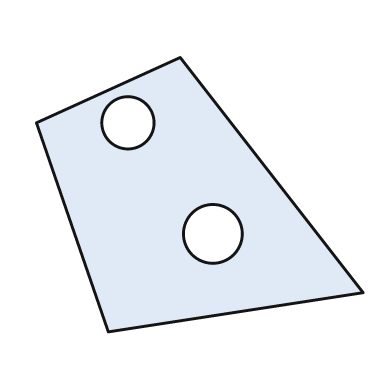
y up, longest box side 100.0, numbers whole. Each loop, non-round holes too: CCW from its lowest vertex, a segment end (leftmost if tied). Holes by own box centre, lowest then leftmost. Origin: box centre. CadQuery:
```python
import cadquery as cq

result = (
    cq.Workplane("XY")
    .moveTo(-28.0, -42.0)
    .lineTo(50.0, -30.0)
    .lineTo(-6.0, 42.0)
    .lineTo(-50.0, 22.0)
    .close()
    .moveTo(4.0, -12.0)
    .circle(9.0)
    .moveTo(-22.0, 22.0)
    .circle(8.0)
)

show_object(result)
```